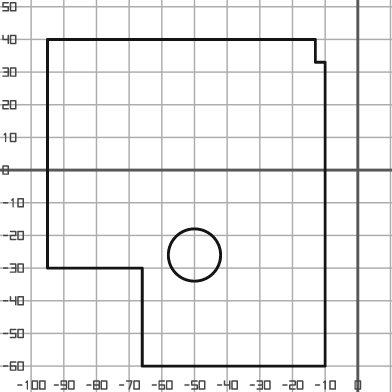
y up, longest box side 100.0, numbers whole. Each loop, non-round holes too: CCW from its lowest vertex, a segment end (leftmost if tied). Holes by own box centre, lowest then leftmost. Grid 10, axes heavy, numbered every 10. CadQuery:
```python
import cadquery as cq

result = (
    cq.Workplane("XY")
    .moveTo(-66.0, -60.0)
    .lineTo(-10.0, -60.0)
    .lineTo(-10.0, 33.0)
    .lineTo(-13.0, 33.0)
    .lineTo(-13.0, 40.0)
    .lineTo(-95.0, 40.0)
    .lineTo(-95.0, -30.0)
    .lineTo(-66.0, -30.0)
    .close()
    .moveTo(-50.0, -26.0)
    .circle(8.0)
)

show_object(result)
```